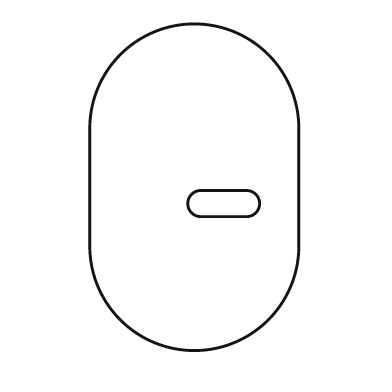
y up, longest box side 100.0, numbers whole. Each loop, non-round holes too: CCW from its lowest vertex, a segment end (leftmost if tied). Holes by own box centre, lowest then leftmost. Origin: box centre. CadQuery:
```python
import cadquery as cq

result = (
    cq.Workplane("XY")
    .moveTo(-32.0, -18.0)
    .threePointArc((0.0, -50.0), (32.0, -18.0))
    .lineTo(32.0, 18.0)
    .threePointArc((0.0, 50.0), (-32.0, 18.0))
    .close()
    .moveTo(2.0, -9.0)
    .lineTo(16.0, -9.0)
    .threePointArc((20.0, -5.0), (16.0, -1.0))
    .lineTo(2.0, -1.0)
    .threePointArc((-2.0, -5.0), (2.0, -9.0))
    .close()
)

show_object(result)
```